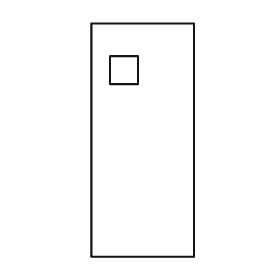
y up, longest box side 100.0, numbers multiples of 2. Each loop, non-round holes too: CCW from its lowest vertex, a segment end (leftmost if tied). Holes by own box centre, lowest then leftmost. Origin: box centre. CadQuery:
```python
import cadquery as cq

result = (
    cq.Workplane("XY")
    .moveTo(-22.0, -50.0)
    .lineTo(22.0, -50.0)
    .lineTo(22.0, 50.0)
    .lineTo(-22.0, 50.0)
    .close()
    .moveTo(-14.0, 24.0)
    .lineTo(-2.0, 24.0)
    .lineTo(-2.0, 36.0)
    .lineTo(-14.0, 36.0)
    .close()
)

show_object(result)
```